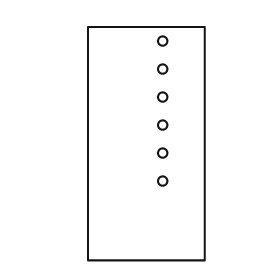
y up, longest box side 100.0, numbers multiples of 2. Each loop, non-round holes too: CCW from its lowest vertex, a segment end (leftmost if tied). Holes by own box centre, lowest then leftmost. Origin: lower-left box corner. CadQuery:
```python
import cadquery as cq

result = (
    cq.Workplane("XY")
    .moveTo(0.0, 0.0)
    .lineTo(50.0, 0.0)
    .lineTo(50.0, 100.0)
    .lineTo(0.0, 100.0)
    .close()
    .moveTo(32.0, 34.0)
    .circle(2.0)
    .moveTo(32.0, 46.0)
    .circle(2.0)
    .moveTo(32.0, 58.0)
    .circle(2.0)
    .moveTo(32.0, 70.0)
    .circle(2.0)
    .moveTo(32.0, 82.0)
    .circle(2.0)
    .moveTo(32.0, 94.0)
    .circle(2.0)
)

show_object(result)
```